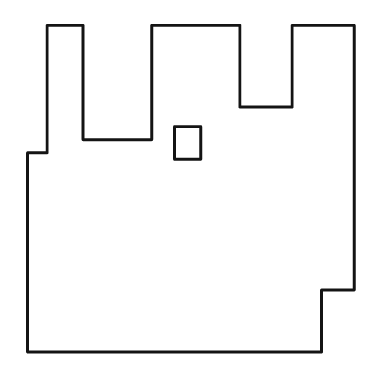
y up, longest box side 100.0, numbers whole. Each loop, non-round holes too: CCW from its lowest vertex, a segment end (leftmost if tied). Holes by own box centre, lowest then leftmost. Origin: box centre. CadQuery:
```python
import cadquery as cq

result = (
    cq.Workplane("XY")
    .moveTo(-50.0, -50.0)
    .lineTo(40.0, -50.0)
    .lineTo(40.0, -31.0)
    .lineTo(50.0, -31.0)
    .lineTo(50.0, 50.0)
    .lineTo(31.0, 50.0)
    .lineTo(31.0, 25.0)
    .lineTo(15.0, 25.0)
    .lineTo(15.0, 50.0)
    .lineTo(-12.0, 50.0)
    .lineTo(-12.0, 15.0)
    .lineTo(-33.0, 15.0)
    .lineTo(-33.0, 50.0)
    .lineTo(-44.0, 50.0)
    .lineTo(-44.0, 11.0)
    .lineTo(-50.0, 11.0)
    .close()
    .moveTo(-5.0, 9.0)
    .lineTo(3.0, 9.0)
    .lineTo(3.0, 19.0)
    .lineTo(-5.0, 19.0)
    .close()
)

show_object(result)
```